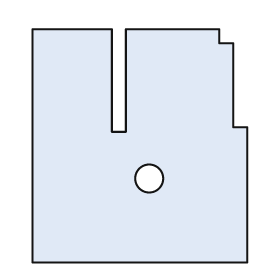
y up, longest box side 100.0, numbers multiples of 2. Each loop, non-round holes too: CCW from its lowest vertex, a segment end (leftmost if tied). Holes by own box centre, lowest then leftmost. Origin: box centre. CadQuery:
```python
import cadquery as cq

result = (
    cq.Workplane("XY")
    .moveTo(-46.0, -50.0)
    .lineTo(46.0, -50.0)
    .lineTo(46.0, 8.0)
    .lineTo(40.0, 8.0)
    .lineTo(40.0, 44.0)
    .lineTo(34.0, 44.0)
    .lineTo(34.0, 50.0)
    .lineTo(-6.0, 50.0)
    .lineTo(-6.0, 6.0)
    .lineTo(-12.0, 6.0)
    .lineTo(-12.0, 50.0)
    .lineTo(-46.0, 50.0)
    .close()
    .moveTo(4.0, -14.0)
    .circle(6.0)
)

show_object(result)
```